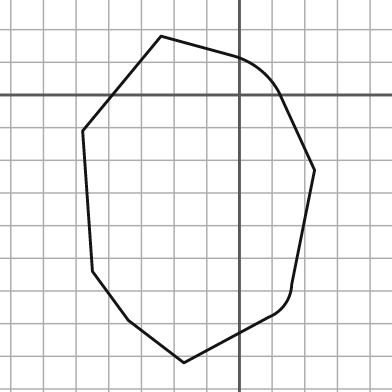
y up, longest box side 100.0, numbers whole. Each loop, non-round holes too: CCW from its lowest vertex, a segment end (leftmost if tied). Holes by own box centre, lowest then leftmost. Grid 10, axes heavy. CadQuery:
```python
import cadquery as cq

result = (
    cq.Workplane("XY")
    .moveTo(-17.0, -82.0)
    .lineTo(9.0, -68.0)
    .threePointArc((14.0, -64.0), (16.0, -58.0))
    .lineTo(23.0, -23.0)
    .lineTo(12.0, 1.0)
    .threePointArc((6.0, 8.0), (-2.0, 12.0))
    .lineTo(-24.0, 18.0)
    .lineTo(-48.0, -11.0)
    .lineTo(-45.0, -54.0)
    .lineTo(-34.0, -69.0)
    .close()
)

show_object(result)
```